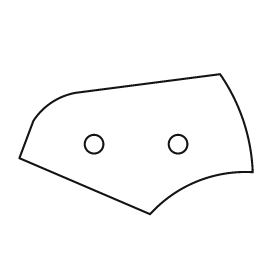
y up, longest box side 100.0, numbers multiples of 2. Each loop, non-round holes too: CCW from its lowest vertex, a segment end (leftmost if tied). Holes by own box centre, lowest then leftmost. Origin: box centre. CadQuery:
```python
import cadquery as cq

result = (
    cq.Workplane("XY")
    .moveTo(6.0, -30.0)
    .threePointArc((26.0, -16.0), (50.0, -12.0))
    .threePointArc((46.0, 10.0), (36.0, 30.0))
    .lineTo(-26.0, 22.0)
    .threePointArc((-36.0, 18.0), (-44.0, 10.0))
    .lineTo(-50.0, -6.0)
    .close()
    .moveTo(-18.0, 0.0)
    .circle(4.0)
    .moveTo(18.0, 0.0)
    .circle(4.0)
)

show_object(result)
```